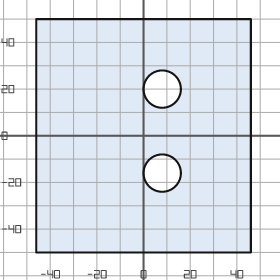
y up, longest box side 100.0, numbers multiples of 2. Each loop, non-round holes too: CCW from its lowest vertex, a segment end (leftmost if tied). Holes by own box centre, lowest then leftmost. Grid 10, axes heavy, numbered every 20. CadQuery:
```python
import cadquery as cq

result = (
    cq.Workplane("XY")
    .moveTo(-46.0, -50.0)
    .lineTo(46.0, -50.0)
    .lineTo(46.0, 50.0)
    .lineTo(-46.0, 50.0)
    .close()
    .moveTo(8.0, -16.0)
    .circle(8.0)
    .moveTo(8.0, 20.0)
    .circle(8.0)
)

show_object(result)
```